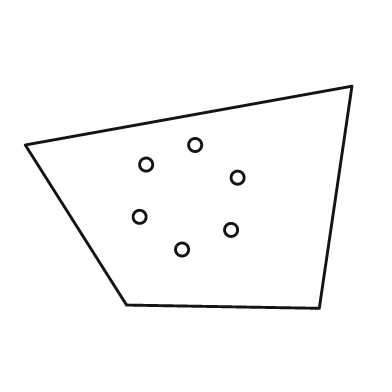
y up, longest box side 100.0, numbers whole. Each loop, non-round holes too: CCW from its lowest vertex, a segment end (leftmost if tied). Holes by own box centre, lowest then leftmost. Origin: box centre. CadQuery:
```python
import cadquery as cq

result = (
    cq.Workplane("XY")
    .moveTo(40.0, -34.0)
    .lineTo(50.0, 34.0)
    .lineTo(-50.0, 16.0)
    .lineTo(-19.0, -33.0)
    .close()
    .moveTo(-2.0, -16.0)
    .circle(2.0)
    .moveTo(13.0, -10.0)
    .circle(2.0)
    .moveTo(-15.0, -6.0)
    .circle(2.0)
    .moveTo(15.0, 6.0)
    .circle(2.0)
    .moveTo(-13.0, 10.0)
    .circle(2.0)
    .moveTo(2.0, 16.0)
    .circle(2.0)
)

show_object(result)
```